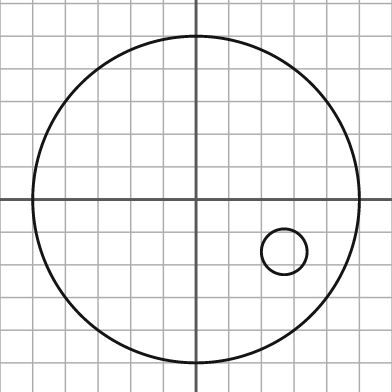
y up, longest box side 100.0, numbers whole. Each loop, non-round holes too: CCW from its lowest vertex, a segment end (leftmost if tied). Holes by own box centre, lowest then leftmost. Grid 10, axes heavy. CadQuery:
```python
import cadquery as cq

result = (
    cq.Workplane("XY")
    .moveTo(0.0, 0.0)
    .circle(50.0)
    .moveTo(27.0, -16.0)
    .circle(7.0)
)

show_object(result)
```